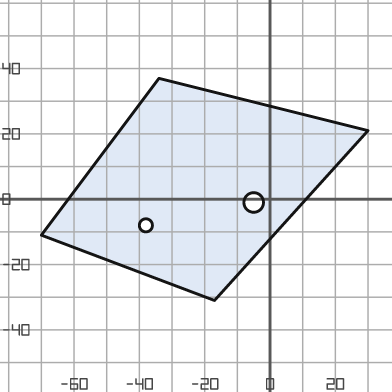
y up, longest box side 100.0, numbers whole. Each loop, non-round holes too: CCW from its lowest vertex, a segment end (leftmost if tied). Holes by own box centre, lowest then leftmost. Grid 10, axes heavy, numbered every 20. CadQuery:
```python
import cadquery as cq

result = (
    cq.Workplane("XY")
    .moveTo(-17.0, -31.0)
    .lineTo(30.0, 21.0)
    .lineTo(-34.0, 37.0)
    .lineTo(-70.0, -11.0)
    .close()
    .moveTo(-38.0, -8.0)
    .circle(2.0)
    .moveTo(-5.0, -1.0)
    .circle(3.0)
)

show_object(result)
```